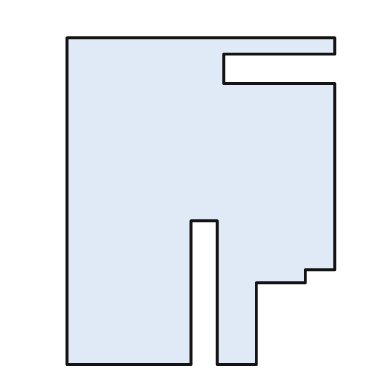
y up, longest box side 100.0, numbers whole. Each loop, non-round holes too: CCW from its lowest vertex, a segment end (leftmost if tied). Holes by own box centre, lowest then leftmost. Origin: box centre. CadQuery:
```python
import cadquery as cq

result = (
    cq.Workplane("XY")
    .moveTo(-41.0, -50.0)
    .lineTo(-3.0, -50.0)
    .lineTo(-3.0, -6.0)
    .lineTo(5.0, -6.0)
    .lineTo(5.0, -50.0)
    .lineTo(17.0, -50.0)
    .lineTo(17.0, -25.0)
    .lineTo(32.0, -25.0)
    .lineTo(32.0, -21.0)
    .lineTo(41.0, -21.0)
    .lineTo(41.0, 36.0)
    .lineTo(7.0, 36.0)
    .lineTo(7.0, 45.0)
    .lineTo(41.0, 45.0)
    .lineTo(41.0, 50.0)
    .lineTo(-41.0, 50.0)
    .close()
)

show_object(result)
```